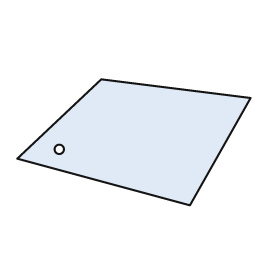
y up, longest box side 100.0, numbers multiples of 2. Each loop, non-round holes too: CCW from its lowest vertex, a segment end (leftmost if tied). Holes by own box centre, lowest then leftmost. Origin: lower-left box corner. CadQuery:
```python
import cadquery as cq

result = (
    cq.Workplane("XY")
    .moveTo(74.0, 0.0)
    .lineTo(100.0, 46.0)
    .lineTo(36.0, 54.0)
    .lineTo(0.0, 20.0)
    .close()
    .moveTo(18.0, 24.0)
    .circle(2.0)
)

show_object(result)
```